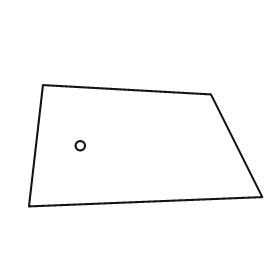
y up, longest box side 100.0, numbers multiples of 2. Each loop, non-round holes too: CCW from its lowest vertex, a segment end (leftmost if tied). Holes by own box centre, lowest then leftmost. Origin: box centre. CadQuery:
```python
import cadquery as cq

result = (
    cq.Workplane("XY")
    .moveTo(-50.0, -26.0)
    .lineTo(50.0, -22.0)
    .lineTo(28.0, 22.0)
    .lineTo(-44.0, 26.0)
    .close()
    .moveTo(-28.0, 0.0)
    .circle(2.0)
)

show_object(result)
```